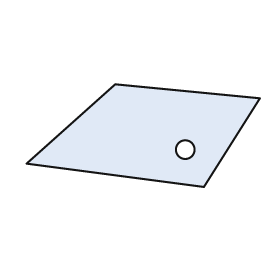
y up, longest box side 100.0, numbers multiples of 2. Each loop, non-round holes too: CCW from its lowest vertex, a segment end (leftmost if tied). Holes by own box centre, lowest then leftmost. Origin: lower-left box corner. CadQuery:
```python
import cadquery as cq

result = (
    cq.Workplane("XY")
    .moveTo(76.0, 0.0)
    .lineTo(100.0, 38.0)
    .lineTo(38.0, 44.0)
    .lineTo(0.0, 10.0)
    .close()
    .moveTo(68.0, 16.0)
    .circle(4.0)
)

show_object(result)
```